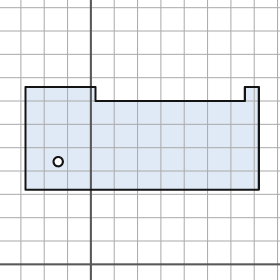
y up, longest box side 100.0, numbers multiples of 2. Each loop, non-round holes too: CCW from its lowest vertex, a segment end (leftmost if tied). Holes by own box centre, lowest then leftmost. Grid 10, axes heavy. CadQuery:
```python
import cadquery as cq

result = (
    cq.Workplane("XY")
    .moveTo(-28.0, 32.0)
    .lineTo(72.0, 32.0)
    .lineTo(72.0, 76.0)
    .lineTo(66.0, 76.0)
    .lineTo(66.0, 70.0)
    .lineTo(2.0, 70.0)
    .lineTo(2.0, 76.0)
    .lineTo(-28.0, 76.0)
    .close()
    .moveTo(-14.0, 44.0)
    .circle(2.0)
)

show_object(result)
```